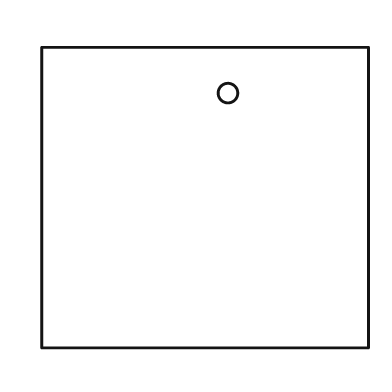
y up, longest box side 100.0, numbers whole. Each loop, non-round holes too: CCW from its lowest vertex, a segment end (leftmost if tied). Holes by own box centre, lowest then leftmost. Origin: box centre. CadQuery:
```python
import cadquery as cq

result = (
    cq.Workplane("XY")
    .moveTo(-50.0, -46.0)
    .lineTo(50.0, -46.0)
    .lineTo(50.0, 46.0)
    .lineTo(-50.0, 46.0)
    .close()
    .moveTo(7.0, 32.0)
    .circle(3.0)
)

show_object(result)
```